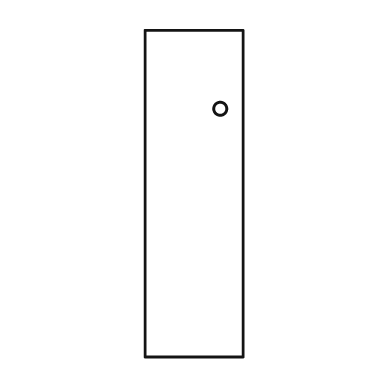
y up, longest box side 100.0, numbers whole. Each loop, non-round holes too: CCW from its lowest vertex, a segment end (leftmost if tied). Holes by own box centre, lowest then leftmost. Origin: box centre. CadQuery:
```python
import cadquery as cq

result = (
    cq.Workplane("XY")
    .moveTo(-15.0, -50.0)
    .lineTo(15.0, -50.0)
    .lineTo(15.0, 50.0)
    .lineTo(-15.0, 50.0)
    .close()
    .moveTo(8.0, 26.0)
    .circle(2.0)
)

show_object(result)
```